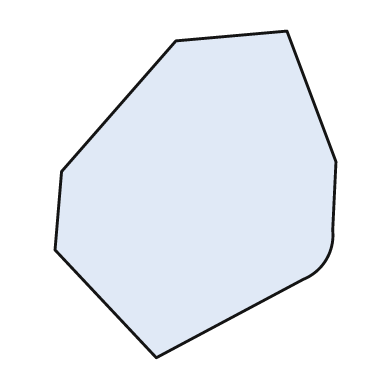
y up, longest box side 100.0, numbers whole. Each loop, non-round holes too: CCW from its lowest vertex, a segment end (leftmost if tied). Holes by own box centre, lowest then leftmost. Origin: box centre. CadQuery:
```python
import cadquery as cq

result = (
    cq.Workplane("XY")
    .moveTo(-12.0, -50.0)
    .lineTo(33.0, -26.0)
    .threePointArc((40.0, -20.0), (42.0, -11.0))
    .lineTo(43.0, 10.0)
    .lineTo(28.0, 50.0)
    .lineTo(-6.0, 47.0)
    .lineTo(-41.0, 7.0)
    .lineTo(-43.0, -17.0)
    .close()
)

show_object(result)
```